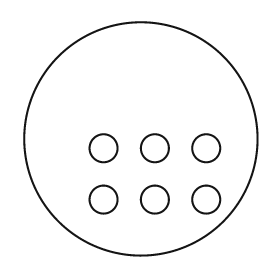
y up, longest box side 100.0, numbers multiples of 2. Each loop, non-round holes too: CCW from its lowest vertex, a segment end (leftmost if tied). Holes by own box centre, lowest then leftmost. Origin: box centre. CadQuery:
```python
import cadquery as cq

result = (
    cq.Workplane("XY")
    .moveTo(0.0, 0.0)
    .circle(50.0)
    .moveTo(-16.0, -26.0)
    .circle(6.0)
    .moveTo(6.0, -26.0)
    .circle(6.0)
    .moveTo(28.0, -26.0)
    .circle(6.0)
    .moveTo(-16.0, -4.0)
    .circle(6.0)
    .moveTo(6.0, -4.0)
    .circle(6.0)
    .moveTo(28.0, -4.0)
    .circle(6.0)
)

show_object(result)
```